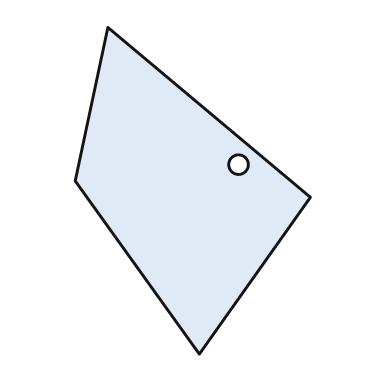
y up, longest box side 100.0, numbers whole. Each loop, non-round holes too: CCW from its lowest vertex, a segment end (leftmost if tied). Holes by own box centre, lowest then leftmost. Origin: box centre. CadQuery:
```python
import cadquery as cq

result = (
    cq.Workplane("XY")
    .moveTo(2.0, -50.0)
    .lineTo(36.0, -2.0)
    .lineTo(-26.0, 50.0)
    .lineTo(-36.0, 3.0)
    .close()
    .moveTo(14.0, 8.0)
    .circle(3.0)
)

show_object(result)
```